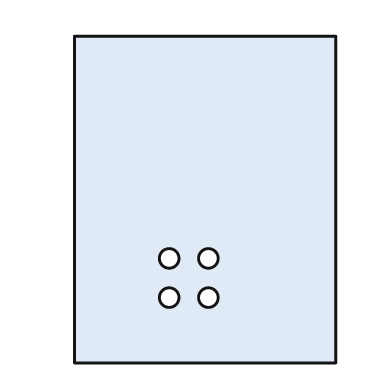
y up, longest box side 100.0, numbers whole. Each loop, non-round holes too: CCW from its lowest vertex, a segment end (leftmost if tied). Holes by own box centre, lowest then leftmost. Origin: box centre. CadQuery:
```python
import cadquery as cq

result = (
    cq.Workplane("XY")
    .moveTo(-40.0, -50.0)
    .lineTo(40.0, -50.0)
    .lineTo(40.0, 50.0)
    .lineTo(-40.0, 50.0)
    .close()
    .moveTo(-11.0, -30.0)
    .circle(3.0)
    .moveTo(1.0, -30.0)
    .circle(3.0)
    .moveTo(-11.0, -18.0)
    .circle(3.0)
    .moveTo(1.0, -18.0)
    .circle(3.0)
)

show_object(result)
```